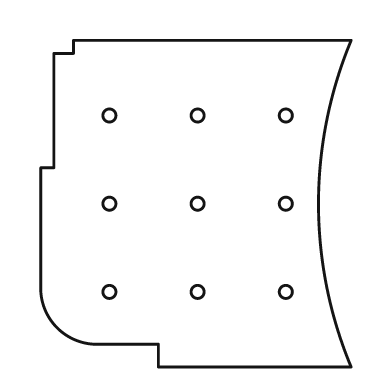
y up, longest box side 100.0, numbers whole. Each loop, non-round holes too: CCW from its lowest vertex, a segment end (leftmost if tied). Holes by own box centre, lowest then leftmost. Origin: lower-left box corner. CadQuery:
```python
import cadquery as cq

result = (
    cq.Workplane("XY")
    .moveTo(36.0, 0.0)
    .lineTo(95.0, 0.0)
    .threePointArc((85.0, 50.0), (95.0, 100.0))
    .lineTo(10.0, 100.0)
    .lineTo(10.0, 96.0)
    .lineTo(4.0, 96.0)
    .lineTo(4.0, 61.0)
    .lineTo(0.0, 61.0)
    .lineTo(0.0, 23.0)
    .threePointArc((5.0, 12.0), (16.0, 7.0))
    .lineTo(36.0, 7.0)
    .close()
    .moveTo(21.0, 23.0)
    .circle(2.0)
    .moveTo(48.0, 23.0)
    .circle(2.0)
    .moveTo(75.0, 23.0)
    .circle(2.0)
    .moveTo(21.0, 50.0)
    .circle(2.0)
    .moveTo(48.0, 50.0)
    .circle(2.0)
    .moveTo(75.0, 50.0)
    .circle(2.0)
    .moveTo(21.0, 77.0)
    .circle(2.0)
    .moveTo(48.0, 77.0)
    .circle(2.0)
    .moveTo(75.0, 77.0)
    .circle(2.0)
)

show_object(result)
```